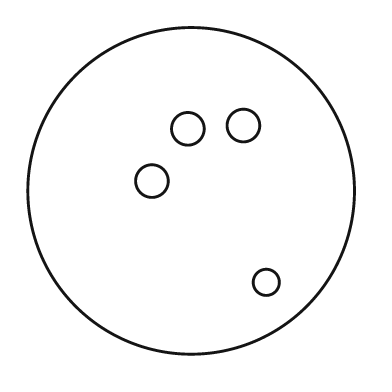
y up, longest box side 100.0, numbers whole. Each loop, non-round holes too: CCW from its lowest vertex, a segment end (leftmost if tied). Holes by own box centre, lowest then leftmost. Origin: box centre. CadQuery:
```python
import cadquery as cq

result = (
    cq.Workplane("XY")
    .moveTo(0.0, 0.0)
    .circle(50.0)
    .moveTo(23.0, -28.0)
    .circle(4.0)
    .moveTo(-12.0, 3.0)
    .circle(5.0)
    .moveTo(-1.0, 19.0)
    .circle(5.0)
    .moveTo(16.0, 20.0)
    .circle(5.0)
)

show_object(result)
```